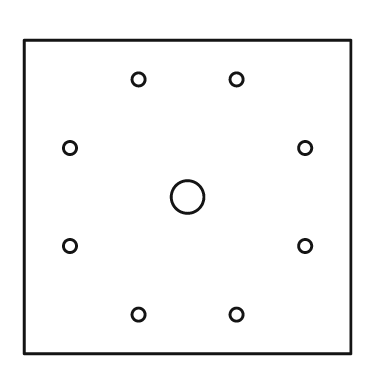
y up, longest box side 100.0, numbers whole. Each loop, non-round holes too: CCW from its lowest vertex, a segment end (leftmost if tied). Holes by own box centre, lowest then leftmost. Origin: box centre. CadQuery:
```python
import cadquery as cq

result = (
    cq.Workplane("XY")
    .moveTo(-50.0, -48.0)
    .lineTo(50.0, -48.0)
    .lineTo(50.0, 48.0)
    .lineTo(-50.0, 48.0)
    .close()
    .moveTo(-15.0, -36.0)
    .circle(2.0)
    .moveTo(15.0, -36.0)
    .circle(2.0)
    .moveTo(-36.0, -15.0)
    .circle(2.0)
    .moveTo(36.0, -15.0)
    .circle(2.0)
    .moveTo(0.0, 0.0)
    .circle(5.0)
    .moveTo(-36.0, 15.0)
    .circle(2.0)
    .moveTo(36.0, 15.0)
    .circle(2.0)
    .moveTo(-15.0, 36.0)
    .circle(2.0)
    .moveTo(15.0, 36.0)
    .circle(2.0)
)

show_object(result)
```